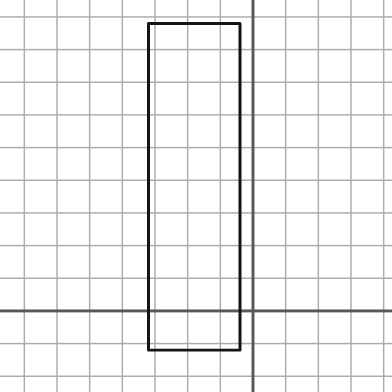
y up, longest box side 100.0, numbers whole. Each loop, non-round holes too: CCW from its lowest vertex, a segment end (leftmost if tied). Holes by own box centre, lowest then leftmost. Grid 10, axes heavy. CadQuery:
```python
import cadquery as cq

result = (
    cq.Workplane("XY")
    .moveTo(-32.0, -12.0)
    .lineTo(-4.0, -12.0)
    .lineTo(-4.0, 88.0)
    .lineTo(-32.0, 88.0)
    .close()
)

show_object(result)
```